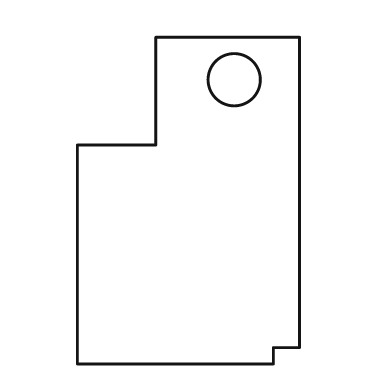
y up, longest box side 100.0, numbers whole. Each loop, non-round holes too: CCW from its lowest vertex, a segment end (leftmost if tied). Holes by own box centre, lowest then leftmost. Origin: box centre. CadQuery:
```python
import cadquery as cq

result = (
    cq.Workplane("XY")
    .moveTo(-34.0, -50.0)
    .lineTo(26.0, -50.0)
    .lineTo(26.0, -45.0)
    .lineTo(34.0, -45.0)
    .lineTo(34.0, 50.0)
    .lineTo(-10.0, 50.0)
    .lineTo(-10.0, 17.0)
    .lineTo(-34.0, 17.0)
    .close()
    .moveTo(14.0, 37.0)
    .circle(8.0)
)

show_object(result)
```